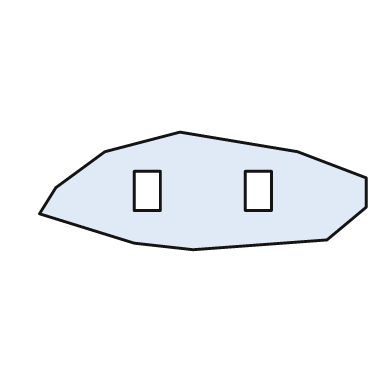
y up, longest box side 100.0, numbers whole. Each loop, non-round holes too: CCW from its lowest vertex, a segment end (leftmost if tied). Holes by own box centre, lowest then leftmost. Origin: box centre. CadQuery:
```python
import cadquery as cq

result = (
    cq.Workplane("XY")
    .moveTo(-3.0, -18.0)
    .lineTo(38.0, -15.0)
    .lineTo(50.0, -5.0)
    .lineTo(50.0, 4.0)
    .lineTo(29.0, 12.0)
    .lineTo(-7.0, 18.0)
    .lineTo(-30.0, 12.0)
    .lineTo(-45.0, 1.0)
    .lineTo(-50.0, -7.0)
    .lineTo(-21.0, -16.0)
    .close()
    .moveTo(-21.0, -6.0)
    .lineTo(-13.0, -6.0)
    .lineTo(-13.0, 6.0)
    .lineTo(-21.0, 6.0)
    .close()
    .moveTo(13.0, -6.0)
    .lineTo(21.0, -6.0)
    .lineTo(21.0, 6.0)
    .lineTo(13.0, 6.0)
    .close()
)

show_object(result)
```